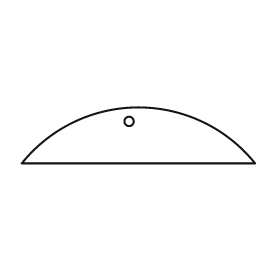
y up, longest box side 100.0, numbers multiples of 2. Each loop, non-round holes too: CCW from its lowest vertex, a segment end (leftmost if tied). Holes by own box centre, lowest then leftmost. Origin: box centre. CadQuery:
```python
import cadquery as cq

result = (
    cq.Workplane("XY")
    .moveTo(-50.0, -12.0)
    .lineTo(50.0, -12.0)
    .threePointArc((0.0, 12.0), (-50.0, -12.0))
    .close()
    .moveTo(-4.0, 6.0)
    .circle(2.0)
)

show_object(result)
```